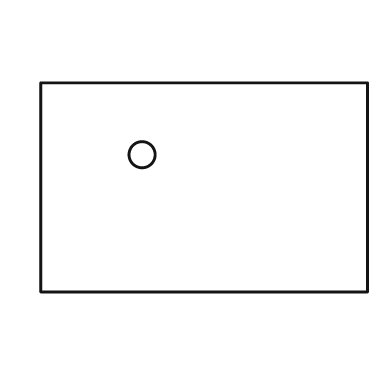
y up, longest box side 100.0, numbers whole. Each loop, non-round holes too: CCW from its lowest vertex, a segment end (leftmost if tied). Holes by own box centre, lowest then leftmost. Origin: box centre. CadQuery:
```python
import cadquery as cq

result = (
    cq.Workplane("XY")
    .moveTo(-50.0, -32.0)
    .lineTo(50.0, -32.0)
    .lineTo(50.0, 32.0)
    .lineTo(-50.0, 32.0)
    .close()
    .moveTo(-19.0, 10.0)
    .circle(4.0)
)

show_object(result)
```